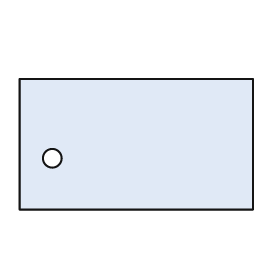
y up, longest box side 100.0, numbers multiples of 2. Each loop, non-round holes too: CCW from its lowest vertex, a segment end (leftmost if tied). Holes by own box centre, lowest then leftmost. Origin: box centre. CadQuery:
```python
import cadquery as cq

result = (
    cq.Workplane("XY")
    .moveTo(-50.0, -28.0)
    .lineTo(50.0, -28.0)
    .lineTo(50.0, 28.0)
    .lineTo(-50.0, 28.0)
    .close()
    .moveTo(-36.0, -6.0)
    .circle(4.0)
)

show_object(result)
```